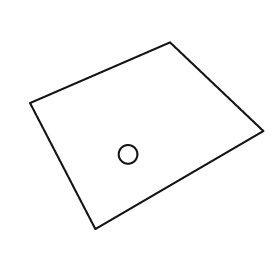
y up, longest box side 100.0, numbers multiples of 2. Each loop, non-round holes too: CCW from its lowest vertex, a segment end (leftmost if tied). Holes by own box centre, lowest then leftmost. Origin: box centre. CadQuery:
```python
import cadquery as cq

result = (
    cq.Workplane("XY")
    .moveTo(-22.0, -40.0)
    .lineTo(50.0, 2.0)
    .lineTo(10.0, 40.0)
    .lineTo(-50.0, 14.0)
    .close()
    .moveTo(-8.0, -8.0)
    .circle(4.0)
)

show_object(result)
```